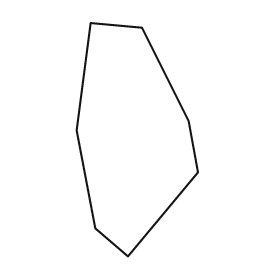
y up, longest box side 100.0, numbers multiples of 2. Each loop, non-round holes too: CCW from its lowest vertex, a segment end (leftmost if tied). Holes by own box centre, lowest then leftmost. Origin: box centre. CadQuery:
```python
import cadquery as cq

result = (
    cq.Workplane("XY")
    .moveTo(-4.0, -50.0)
    .lineTo(26.0, -14.0)
    .lineTo(22.0, 8.0)
    .lineTo(2.0, 48.0)
    .lineTo(-20.0, 50.0)
    .lineTo(-26.0, 4.0)
    .lineTo(-18.0, -38.0)
    .close()
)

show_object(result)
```